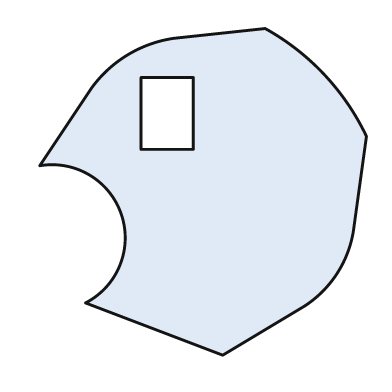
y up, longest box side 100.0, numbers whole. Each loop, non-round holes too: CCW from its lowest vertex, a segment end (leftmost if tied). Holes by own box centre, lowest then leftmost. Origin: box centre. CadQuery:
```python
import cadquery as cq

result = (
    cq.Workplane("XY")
    .moveTo(6.0, -50.0)
    .lineTo(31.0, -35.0)
    .threePointArc((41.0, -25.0), (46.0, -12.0))
    .lineTo(50.0, 17.0)
    .threePointArc((37.0, 36.0), (19.0, 50.0))
    .lineTo(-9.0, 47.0)
    .threePointArc((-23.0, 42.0), (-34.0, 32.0))
    .lineTo(-50.0, 8.0)
    .threePointArc((-25.0, -7.0), (-36.0, -34.0))
    .close()
    .moveTo(-19.0, 13.0)
    .lineTo(-3.0, 13.0)
    .lineTo(-3.0, 35.0)
    .lineTo(-19.0, 35.0)
    .close()
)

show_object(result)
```